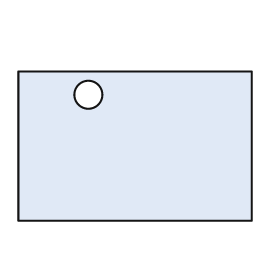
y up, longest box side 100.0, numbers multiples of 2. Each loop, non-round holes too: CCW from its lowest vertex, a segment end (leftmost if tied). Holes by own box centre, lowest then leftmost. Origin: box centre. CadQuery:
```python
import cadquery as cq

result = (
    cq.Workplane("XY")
    .moveTo(-50.0, -32.0)
    .lineTo(50.0, -32.0)
    .lineTo(50.0, 32.0)
    .lineTo(-50.0, 32.0)
    .close()
    .moveTo(-20.0, 22.0)
    .circle(6.0)
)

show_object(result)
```